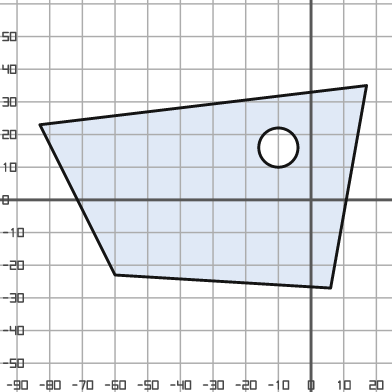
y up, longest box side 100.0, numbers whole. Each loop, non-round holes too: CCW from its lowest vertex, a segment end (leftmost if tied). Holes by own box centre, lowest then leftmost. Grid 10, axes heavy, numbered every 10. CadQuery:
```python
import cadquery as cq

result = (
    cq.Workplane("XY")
    .moveTo(6.0, -27.0)
    .lineTo(17.0, 35.0)
    .lineTo(-83.0, 23.0)
    .lineTo(-60.0, -23.0)
    .close()
    .moveTo(-10.0, 16.0)
    .circle(6.0)
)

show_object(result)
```